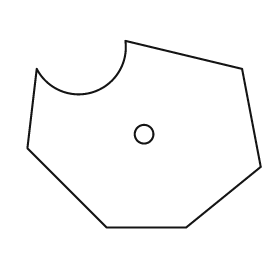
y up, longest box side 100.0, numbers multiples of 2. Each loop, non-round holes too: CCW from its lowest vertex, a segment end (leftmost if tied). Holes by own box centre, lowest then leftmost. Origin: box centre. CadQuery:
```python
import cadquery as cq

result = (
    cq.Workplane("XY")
    .moveTo(-16.0, -40.0)
    .lineTo(18.0, -40.0)
    .lineTo(50.0, -14.0)
    .lineTo(42.0, 28.0)
    .lineTo(-8.0, 40.0)
    .threePointArc((-22.0, 18.0), (-46.0, 28.0))
    .lineTo(-50.0, -6.0)
    .close()
    .moveTo(0.0, 0.0)
    .circle(4.0)
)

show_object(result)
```